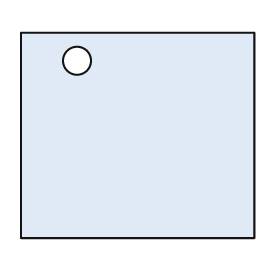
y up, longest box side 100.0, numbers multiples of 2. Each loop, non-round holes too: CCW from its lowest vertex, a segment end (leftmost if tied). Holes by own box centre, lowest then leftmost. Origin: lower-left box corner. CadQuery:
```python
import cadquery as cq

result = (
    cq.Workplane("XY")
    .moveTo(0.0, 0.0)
    .lineTo(100.0, 0.0)
    .lineTo(100.0, 88.0)
    .lineTo(0.0, 88.0)
    .close()
    .moveTo(24.0, 76.0)
    .circle(6.0)
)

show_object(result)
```